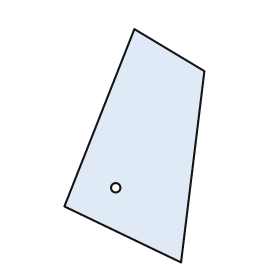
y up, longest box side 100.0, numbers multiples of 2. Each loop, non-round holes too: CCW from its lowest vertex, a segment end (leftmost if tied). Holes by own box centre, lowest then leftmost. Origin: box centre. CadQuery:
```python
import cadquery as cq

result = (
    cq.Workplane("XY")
    .moveTo(20.0, -50.0)
    .lineTo(30.0, 32.0)
    .lineTo(0.0, 50.0)
    .lineTo(-30.0, -26.0)
    .close()
    .moveTo(-8.0, -18.0)
    .circle(2.0)
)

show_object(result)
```